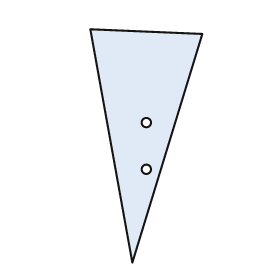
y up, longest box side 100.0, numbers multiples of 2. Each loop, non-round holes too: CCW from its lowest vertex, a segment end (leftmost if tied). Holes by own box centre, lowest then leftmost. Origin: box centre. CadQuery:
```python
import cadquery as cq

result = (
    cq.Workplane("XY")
    .moveTo(-6.0, -50.0)
    .lineTo(24.0, 48.0)
    .lineTo(-24.0, 50.0)
    .close()
    .moveTo(0.0, -10.0)
    .circle(2.0)
    .moveTo(0.0, 10.0)
    .circle(2.0)
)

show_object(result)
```